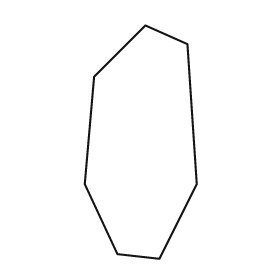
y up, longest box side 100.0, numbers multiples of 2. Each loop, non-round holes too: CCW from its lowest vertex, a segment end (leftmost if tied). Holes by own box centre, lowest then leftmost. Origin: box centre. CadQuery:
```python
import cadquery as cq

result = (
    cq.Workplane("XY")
    .moveTo(8.0, -50.0)
    .lineTo(24.0, -18.0)
    .lineTo(20.0, 42.0)
    .lineTo(2.0, 50.0)
    .lineTo(-20.0, 28.0)
    .lineTo(-24.0, -18.0)
    .lineTo(-10.0, -48.0)
    .close()
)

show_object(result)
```